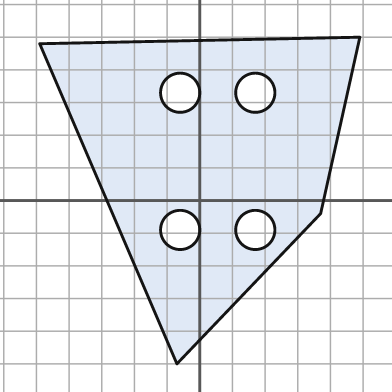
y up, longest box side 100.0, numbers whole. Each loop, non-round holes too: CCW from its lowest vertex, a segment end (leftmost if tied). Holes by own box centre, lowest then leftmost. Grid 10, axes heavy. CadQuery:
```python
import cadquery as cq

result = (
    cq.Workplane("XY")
    .moveTo(-7.0, -50.0)
    .lineTo(37.0, -4.0)
    .lineTo(49.0, 50.0)
    .lineTo(-49.0, 48.0)
    .close()
    .moveTo(-6.0, -9.0)
    .circle(6.0)
    .moveTo(17.0, -9.0)
    .circle(6.0)
    .moveTo(-6.0, 33.0)
    .circle(6.0)
    .moveTo(17.0, 33.0)
    .circle(6.0)
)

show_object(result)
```